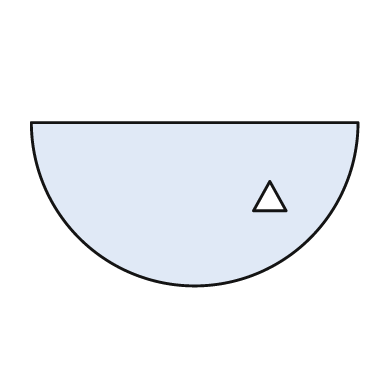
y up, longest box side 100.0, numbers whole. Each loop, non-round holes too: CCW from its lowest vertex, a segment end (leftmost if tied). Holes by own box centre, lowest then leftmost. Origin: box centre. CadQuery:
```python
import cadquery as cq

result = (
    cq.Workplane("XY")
    .moveTo(-50.0, 25.0)
    .threePointArc((0.0, -25.0), (50.0, 25.0))
    .close()
    .moveTo(18.0, -2.0)
    .lineTo(28.0, -2.0)
    .lineTo(23.0, 7.0)
    .close()
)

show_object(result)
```